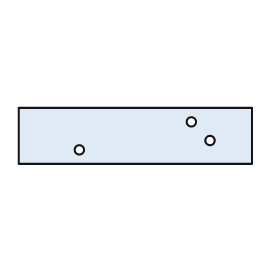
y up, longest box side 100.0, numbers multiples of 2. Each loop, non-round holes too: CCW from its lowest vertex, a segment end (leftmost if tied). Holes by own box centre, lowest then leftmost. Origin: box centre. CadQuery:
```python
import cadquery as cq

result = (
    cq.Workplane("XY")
    .moveTo(-50.0, -12.0)
    .lineTo(50.0, -12.0)
    .lineTo(50.0, 12.0)
    .lineTo(-50.0, 12.0)
    .close()
    .moveTo(-24.0, -6.0)
    .circle(2.0)
    .moveTo(32.0, -2.0)
    .circle(2.0)
    .moveTo(24.0, 6.0)
    .circle(2.0)
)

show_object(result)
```